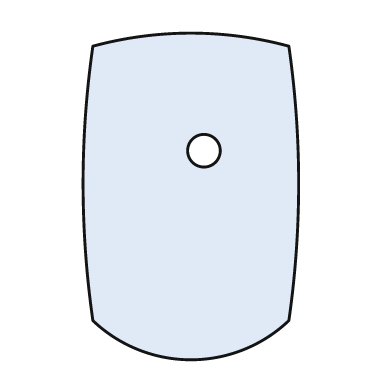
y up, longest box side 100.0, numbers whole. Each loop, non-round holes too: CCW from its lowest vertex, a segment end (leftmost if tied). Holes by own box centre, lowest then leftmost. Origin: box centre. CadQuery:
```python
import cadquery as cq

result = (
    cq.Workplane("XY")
    .moveTo(-30.0, -38.0)
    .threePointArc((0.0, -50.0), (30.0, -38.0))
    .threePointArc((33.0, 4.0), (30.0, 46.0))
    .threePointArc((0.0, 50.0), (-30.0, 46.0))
    .threePointArc((-33.0, 4.0), (-30.0, -38.0))
    .close()
    .moveTo(4.0, 14.0)
    .circle(5.0)
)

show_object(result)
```